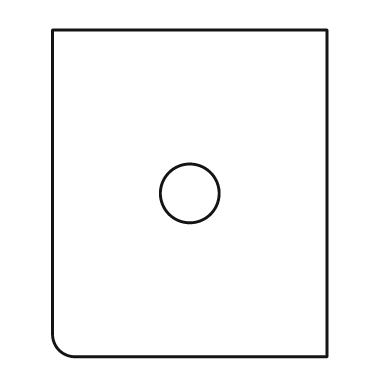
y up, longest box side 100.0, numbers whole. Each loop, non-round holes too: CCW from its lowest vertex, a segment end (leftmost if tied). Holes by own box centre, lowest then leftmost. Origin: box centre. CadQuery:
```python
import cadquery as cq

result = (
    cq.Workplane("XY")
    .moveTo(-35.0, -50.0)
    .lineTo(42.0, -50.0)
    .lineTo(42.0, 50.0)
    .lineTo(-42.0, 50.0)
    .lineTo(-42.0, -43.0)
    .threePointArc((-40.0, -48.0), (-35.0, -50.0))
    .close()
    .moveTo(0.0, 0.0)
    .circle(9.0)
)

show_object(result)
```